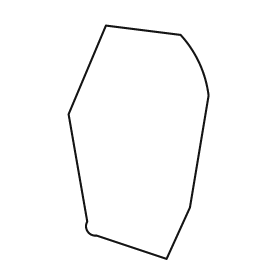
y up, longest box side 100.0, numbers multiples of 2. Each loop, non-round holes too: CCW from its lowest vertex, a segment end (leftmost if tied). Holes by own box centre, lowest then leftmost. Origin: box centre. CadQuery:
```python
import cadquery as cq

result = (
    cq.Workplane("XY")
    .moveTo(12.0, -50.0)
    .lineTo(22.0, -28.0)
    .lineTo(30.0, 20.0)
    .threePointArc((26.0, 34.0), (18.0, 46.0))
    .lineTo(-14.0, 50.0)
    .lineTo(-30.0, 12.0)
    .lineTo(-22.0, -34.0)
    .threePointArc((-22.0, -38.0), (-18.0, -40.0))
    .close()
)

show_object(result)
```